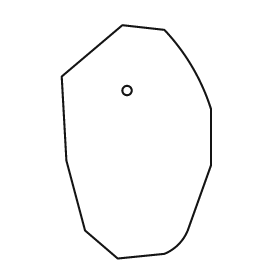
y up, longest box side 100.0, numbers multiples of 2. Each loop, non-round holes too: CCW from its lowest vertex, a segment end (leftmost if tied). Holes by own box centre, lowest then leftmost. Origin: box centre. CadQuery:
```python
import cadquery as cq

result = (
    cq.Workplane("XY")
    .moveTo(-8.0, -50.0)
    .lineTo(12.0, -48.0)
    .threePointArc((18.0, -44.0), (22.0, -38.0))
    .lineTo(32.0, -10.0)
    .lineTo(32.0, 14.0)
    .threePointArc((24.0, 32.0), (12.0, 48.0))
    .lineTo(-6.0, 50.0)
    .lineTo(-32.0, 28.0)
    .lineTo(-30.0, -8.0)
    .lineTo(-22.0, -38.0)
    .close()
    .moveTo(-4.0, 22.0)
    .circle(2.0)
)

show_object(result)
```